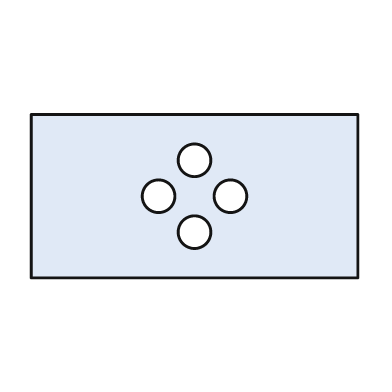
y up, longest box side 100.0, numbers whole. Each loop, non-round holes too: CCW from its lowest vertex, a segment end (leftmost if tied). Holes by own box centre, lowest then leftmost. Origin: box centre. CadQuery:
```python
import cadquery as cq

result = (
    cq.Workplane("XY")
    .moveTo(-50.0, -25.0)
    .lineTo(50.0, -25.0)
    .lineTo(50.0, 25.0)
    .lineTo(-50.0, 25.0)
    .close()
    .moveTo(0.0, -11.0)
    .circle(5.0)
    .moveTo(-11.0, 0.0)
    .circle(5.0)
    .moveTo(11.0, 0.0)
    .circle(5.0)
    .moveTo(0.0, 11.0)
    .circle(5.0)
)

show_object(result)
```